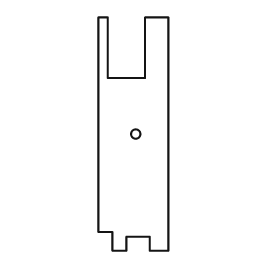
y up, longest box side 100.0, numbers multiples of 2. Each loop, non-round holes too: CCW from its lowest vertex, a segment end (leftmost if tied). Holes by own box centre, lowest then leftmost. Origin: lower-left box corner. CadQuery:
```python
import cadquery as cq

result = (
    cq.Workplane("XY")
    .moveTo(6.0, 0.0)
    .lineTo(12.0, 0.0)
    .lineTo(12.0, 6.0)
    .lineTo(22.0, 6.0)
    .lineTo(22.0, 0.0)
    .lineTo(30.0, 0.0)
    .lineTo(30.0, 100.0)
    .lineTo(20.0, 100.0)
    .lineTo(20.0, 74.0)
    .lineTo(4.0, 74.0)
    .lineTo(4.0, 100.0)
    .lineTo(0.0, 100.0)
    .lineTo(0.0, 8.0)
    .lineTo(6.0, 8.0)
    .close()
    .moveTo(16.0, 50.0)
    .circle(2.0)
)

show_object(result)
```